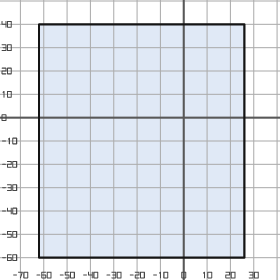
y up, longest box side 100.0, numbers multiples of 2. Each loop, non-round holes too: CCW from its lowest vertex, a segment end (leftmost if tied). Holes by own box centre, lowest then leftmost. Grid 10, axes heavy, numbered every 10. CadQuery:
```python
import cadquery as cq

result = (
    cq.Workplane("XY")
    .moveTo(-62.0, -60.0)
    .lineTo(26.0, -60.0)
    .lineTo(26.0, 40.0)
    .lineTo(-62.0, 40.0)
    .close()
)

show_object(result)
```